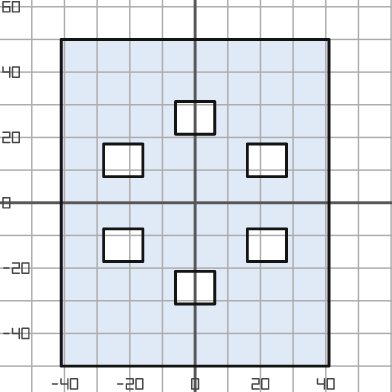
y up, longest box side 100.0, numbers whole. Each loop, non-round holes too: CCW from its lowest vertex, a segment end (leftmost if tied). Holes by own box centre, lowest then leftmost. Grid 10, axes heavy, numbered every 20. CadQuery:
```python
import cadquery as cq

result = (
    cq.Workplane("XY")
    .moveTo(-41.0, -50.0)
    .lineTo(41.0, -50.0)
    .lineTo(41.0, 50.0)
    .lineTo(-41.0, 50.0)
    .close()
    .moveTo(-6.0, -31.0)
    .lineTo(6.0, -31.0)
    .lineTo(6.0, -21.0)
    .lineTo(-6.0, -21.0)
    .close()
    .moveTo(-28.0, -18.0)
    .lineTo(-16.0, -18.0)
    .lineTo(-16.0, -8.0)
    .lineTo(-28.0, -8.0)
    .close()
    .moveTo(16.0, -18.0)
    .lineTo(28.0, -18.0)
    .lineTo(28.0, -8.0)
    .lineTo(16.0, -8.0)
    .close()
    .moveTo(-28.0, 8.0)
    .lineTo(-16.0, 8.0)
    .lineTo(-16.0, 18.0)
    .lineTo(-28.0, 18.0)
    .close()
    .moveTo(16.0, 8.0)
    .lineTo(28.0, 8.0)
    .lineTo(28.0, 18.0)
    .lineTo(16.0, 18.0)
    .close()
    .moveTo(-6.0, 21.0)
    .lineTo(6.0, 21.0)
    .lineTo(6.0, 31.0)
    .lineTo(-6.0, 31.0)
    .close()
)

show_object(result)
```